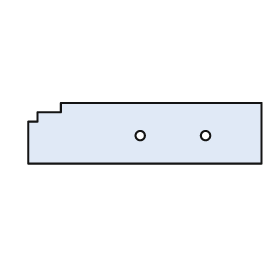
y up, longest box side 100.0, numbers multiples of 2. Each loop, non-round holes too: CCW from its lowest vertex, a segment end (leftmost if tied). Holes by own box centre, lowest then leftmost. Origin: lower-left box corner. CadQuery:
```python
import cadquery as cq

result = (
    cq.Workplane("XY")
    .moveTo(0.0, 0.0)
    .lineTo(100.0, 0.0)
    .lineTo(100.0, 26.0)
    .lineTo(14.0, 26.0)
    .lineTo(14.0, 22.0)
    .lineTo(4.0, 22.0)
    .lineTo(4.0, 18.0)
    .lineTo(0.0, 18.0)
    .close()
    .moveTo(48.0, 12.0)
    .circle(2.0)
    .moveTo(76.0, 12.0)
    .circle(2.0)
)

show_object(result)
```